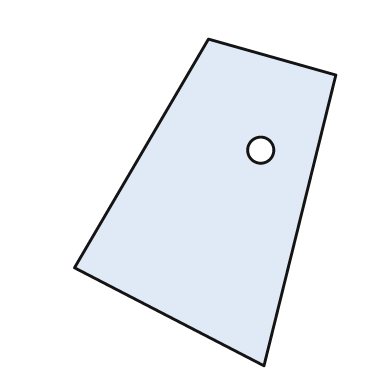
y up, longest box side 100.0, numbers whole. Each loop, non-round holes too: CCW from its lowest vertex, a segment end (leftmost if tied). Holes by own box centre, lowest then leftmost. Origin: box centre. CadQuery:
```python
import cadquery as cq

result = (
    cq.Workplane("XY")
    .moveTo(18.0, -50.0)
    .lineTo(40.0, 39.0)
    .lineTo(1.0, 50.0)
    .lineTo(-40.0, -20.0)
    .close()
    .moveTo(17.0, 16.0)
    .circle(4.0)
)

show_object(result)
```